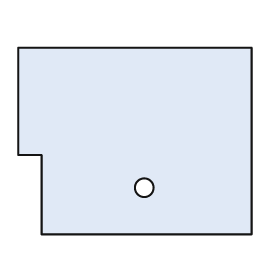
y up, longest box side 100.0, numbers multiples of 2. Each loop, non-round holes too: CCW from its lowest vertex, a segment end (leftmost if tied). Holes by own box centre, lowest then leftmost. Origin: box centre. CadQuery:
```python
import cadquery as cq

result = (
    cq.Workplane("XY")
    .moveTo(-40.0, -40.0)
    .lineTo(50.0, -40.0)
    .lineTo(50.0, 40.0)
    .lineTo(-50.0, 40.0)
    .lineTo(-50.0, -6.0)
    .lineTo(-40.0, -6.0)
    .close()
    .moveTo(4.0, -20.0)
    .circle(4.0)
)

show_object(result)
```